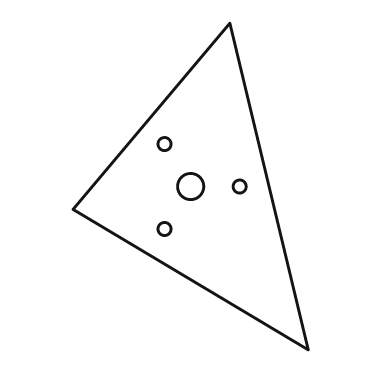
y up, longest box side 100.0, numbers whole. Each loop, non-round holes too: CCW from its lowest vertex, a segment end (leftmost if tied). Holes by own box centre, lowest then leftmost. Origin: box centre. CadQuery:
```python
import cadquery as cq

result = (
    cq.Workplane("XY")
    .moveTo(36.0, -50.0)
    .lineTo(12.0, 50.0)
    .lineTo(-36.0, -7.0)
    .close()
    .moveTo(-8.0, -13.0)
    .circle(2.0)
    .moveTo(0.0, 0.0)
    .circle(4.0)
    .moveTo(15.0, 0.0)
    .circle(2.0)
    .moveTo(-8.0, 13.0)
    .circle(2.0)
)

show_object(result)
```